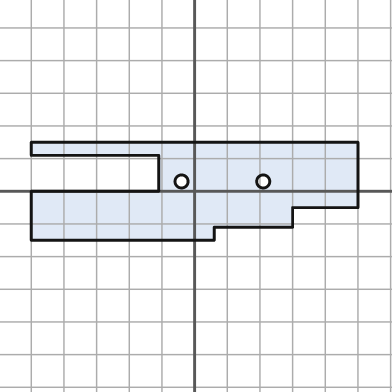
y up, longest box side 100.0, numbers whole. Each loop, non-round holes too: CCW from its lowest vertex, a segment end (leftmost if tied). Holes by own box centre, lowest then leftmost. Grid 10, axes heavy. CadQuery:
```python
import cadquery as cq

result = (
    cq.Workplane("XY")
    .moveTo(-50.0, -15.0)
    .lineTo(6.0, -15.0)
    .lineTo(6.0, -11.0)
    .lineTo(30.0, -11.0)
    .lineTo(30.0, -5.0)
    .lineTo(50.0, -5.0)
    .lineTo(50.0, 15.0)
    .lineTo(-50.0, 15.0)
    .lineTo(-50.0, 11.0)
    .lineTo(-11.0, 11.0)
    .lineTo(-11.0, 0.0)
    .lineTo(-50.0, 0.0)
    .close()
    .moveTo(-4.0, 3.0)
    .circle(2.0)
    .moveTo(21.0, 3.0)
    .circle(2.0)
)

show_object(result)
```